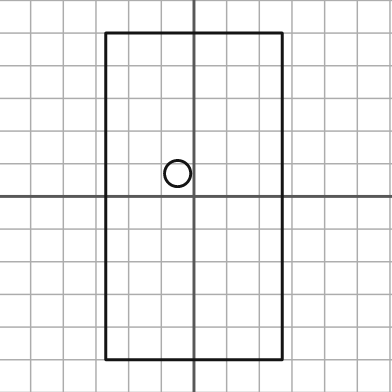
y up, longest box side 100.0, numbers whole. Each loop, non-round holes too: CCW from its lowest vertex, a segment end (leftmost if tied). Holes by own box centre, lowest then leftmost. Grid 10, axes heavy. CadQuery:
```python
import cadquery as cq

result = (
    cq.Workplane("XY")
    .moveTo(-27.0, -50.0)
    .lineTo(27.0, -50.0)
    .lineTo(27.0, 50.0)
    .lineTo(-27.0, 50.0)
    .close()
    .moveTo(-5.0, 7.0)
    .circle(4.0)
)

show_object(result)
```